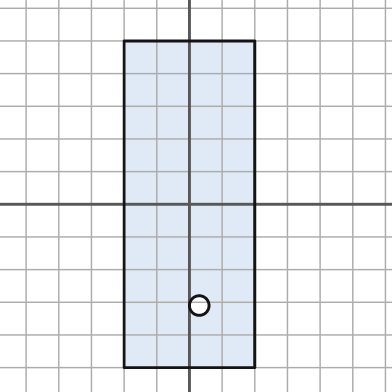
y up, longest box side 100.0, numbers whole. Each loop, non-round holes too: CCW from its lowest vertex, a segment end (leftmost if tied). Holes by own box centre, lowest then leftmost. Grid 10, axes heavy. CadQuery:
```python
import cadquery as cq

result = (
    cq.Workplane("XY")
    .moveTo(-20.0, -50.0)
    .lineTo(20.0, -50.0)
    .lineTo(20.0, 50.0)
    .lineTo(-20.0, 50.0)
    .close()
    .moveTo(3.0, -31.0)
    .circle(3.0)
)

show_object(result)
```